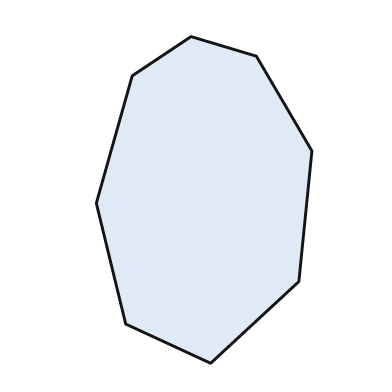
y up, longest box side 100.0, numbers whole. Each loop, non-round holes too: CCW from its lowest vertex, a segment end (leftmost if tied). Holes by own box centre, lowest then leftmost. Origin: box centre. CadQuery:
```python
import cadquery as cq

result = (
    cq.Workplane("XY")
    .moveTo(2.0, -50.0)
    .lineTo(29.0, -25.0)
    .lineTo(33.0, 15.0)
    .lineTo(16.0, 44.0)
    .lineTo(-4.0, 50.0)
    .lineTo(-22.0, 38.0)
    .lineTo(-33.0, -1.0)
    .lineTo(-24.0, -38.0)
    .close()
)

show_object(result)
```